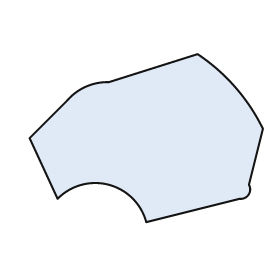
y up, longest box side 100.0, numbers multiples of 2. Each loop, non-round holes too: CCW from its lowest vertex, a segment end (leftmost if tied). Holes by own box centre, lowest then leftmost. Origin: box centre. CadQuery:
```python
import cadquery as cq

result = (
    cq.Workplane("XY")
    .moveTo(0.0, -36.0)
    .lineTo(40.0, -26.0)
    .threePointArc((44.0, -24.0), (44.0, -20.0))
    .lineTo(50.0, 4.0)
    .threePointArc((38.0, 22.0), (22.0, 36.0))
    .lineTo(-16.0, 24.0)
    .threePointArc((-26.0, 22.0), (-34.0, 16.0))
    .lineTo(-50.0, 0.0)
    .lineTo(-38.0, -26.0)
    .threePointArc((-16.0, -20.0), (0.0, -36.0))
    .close()
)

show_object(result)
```